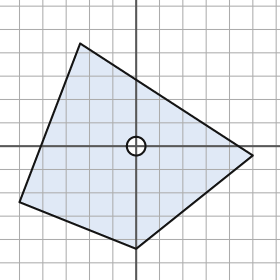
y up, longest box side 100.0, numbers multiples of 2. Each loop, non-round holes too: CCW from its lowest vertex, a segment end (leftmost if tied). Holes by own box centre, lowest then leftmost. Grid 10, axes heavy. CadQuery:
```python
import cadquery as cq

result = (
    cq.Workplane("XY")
    .moveTo(0.0, -44.0)
    .lineTo(50.0, -4.0)
    .lineTo(-24.0, 44.0)
    .lineTo(-50.0, -24.0)
    .close()
    .moveTo(0.0, 0.0)
    .circle(4.0)
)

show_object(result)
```